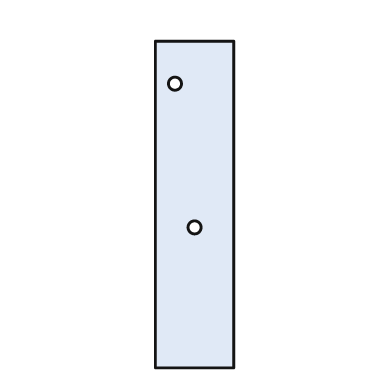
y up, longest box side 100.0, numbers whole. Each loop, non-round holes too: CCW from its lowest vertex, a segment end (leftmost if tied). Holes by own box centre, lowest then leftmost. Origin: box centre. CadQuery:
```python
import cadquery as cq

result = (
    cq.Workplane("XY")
    .moveTo(-12.0, -50.0)
    .lineTo(12.0, -50.0)
    .lineTo(12.0, 50.0)
    .lineTo(-12.0, 50.0)
    .close()
    .moveTo(0.0, -7.0)
    .circle(2.0)
    .moveTo(-6.0, 37.0)
    .circle(2.0)
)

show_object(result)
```